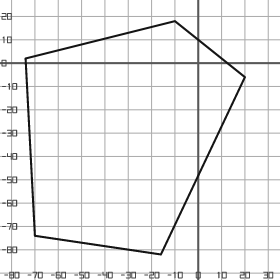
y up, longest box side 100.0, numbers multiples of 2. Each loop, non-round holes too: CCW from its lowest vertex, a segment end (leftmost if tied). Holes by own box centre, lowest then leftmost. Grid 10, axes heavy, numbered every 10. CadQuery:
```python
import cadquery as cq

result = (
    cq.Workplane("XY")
    .moveTo(-16.0, -82.0)
    .lineTo(20.0, -6.0)
    .lineTo(-10.0, 18.0)
    .lineTo(-74.0, 2.0)
    .lineTo(-70.0, -74.0)
    .close()
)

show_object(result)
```